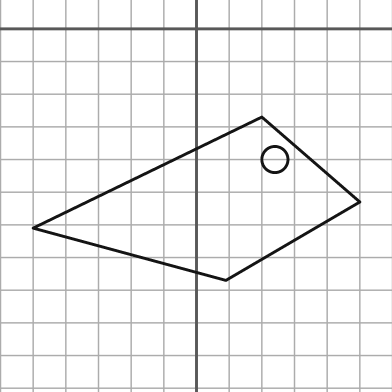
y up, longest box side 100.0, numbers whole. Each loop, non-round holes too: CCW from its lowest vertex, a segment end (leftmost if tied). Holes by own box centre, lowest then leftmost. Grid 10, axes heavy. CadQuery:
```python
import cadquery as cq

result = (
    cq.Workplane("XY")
    .moveTo(9.0, -77.0)
    .lineTo(50.0, -53.0)
    .lineTo(20.0, -27.0)
    .lineTo(-50.0, -61.0)
    .close()
    .moveTo(24.0, -40.0)
    .circle(4.0)
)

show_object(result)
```